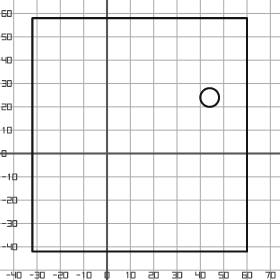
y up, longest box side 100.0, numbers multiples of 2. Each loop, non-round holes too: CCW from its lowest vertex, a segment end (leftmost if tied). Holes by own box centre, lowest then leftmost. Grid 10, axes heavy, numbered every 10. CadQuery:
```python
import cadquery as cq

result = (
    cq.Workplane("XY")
    .moveTo(-32.0, -42.0)
    .lineTo(60.0, -42.0)
    .lineTo(60.0, 58.0)
    .lineTo(-32.0, 58.0)
    .close()
    .moveTo(44.0, 24.0)
    .circle(4.0)
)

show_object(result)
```